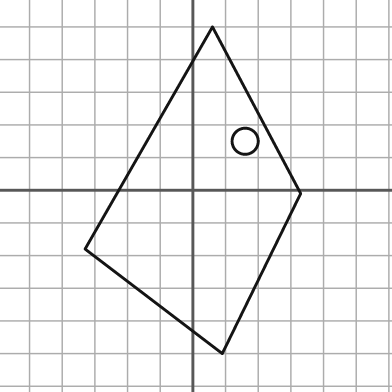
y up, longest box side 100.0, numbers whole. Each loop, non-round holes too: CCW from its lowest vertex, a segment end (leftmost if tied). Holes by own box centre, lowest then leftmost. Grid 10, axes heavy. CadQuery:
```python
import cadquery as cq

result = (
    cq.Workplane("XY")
    .moveTo(9.0, -50.0)
    .lineTo(33.0, -1.0)
    .lineTo(6.0, 50.0)
    .lineTo(-33.0, -18.0)
    .close()
    .moveTo(16.0, 15.0)
    .circle(4.0)
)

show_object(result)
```